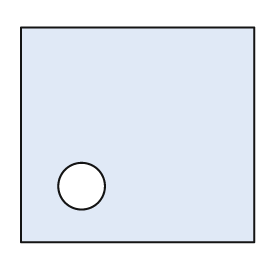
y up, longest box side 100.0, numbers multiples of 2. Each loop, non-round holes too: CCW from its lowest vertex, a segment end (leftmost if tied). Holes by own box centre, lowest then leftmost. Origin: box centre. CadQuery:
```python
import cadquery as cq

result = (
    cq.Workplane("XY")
    .moveTo(-50.0, -46.0)
    .lineTo(50.0, -46.0)
    .lineTo(50.0, 46.0)
    .lineTo(-50.0, 46.0)
    .close()
    .moveTo(-24.0, -22.0)
    .circle(10.0)
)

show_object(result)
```